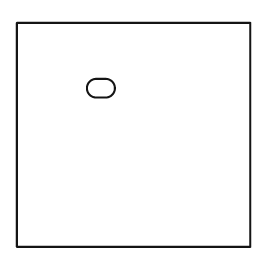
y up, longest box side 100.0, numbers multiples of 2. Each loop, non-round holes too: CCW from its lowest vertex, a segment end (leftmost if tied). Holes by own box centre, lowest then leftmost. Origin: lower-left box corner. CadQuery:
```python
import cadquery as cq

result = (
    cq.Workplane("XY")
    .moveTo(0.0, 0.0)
    .lineTo(100.0, 0.0)
    .lineTo(100.0, 96.0)
    .lineTo(0.0, 96.0)
    .close()
    .moveTo(34.0, 64.0)
    .lineTo(38.0, 64.0)
    .threePointArc((42.0, 68.0), (38.0, 72.0))
    .lineTo(34.0, 72.0)
    .threePointArc((30.0, 68.0), (34.0, 64.0))
    .close()
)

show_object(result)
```